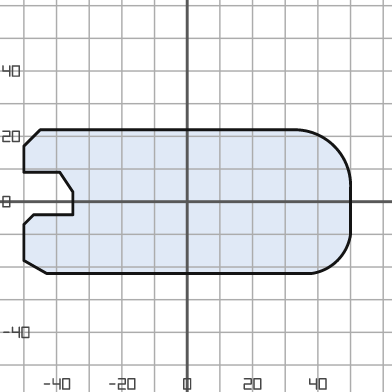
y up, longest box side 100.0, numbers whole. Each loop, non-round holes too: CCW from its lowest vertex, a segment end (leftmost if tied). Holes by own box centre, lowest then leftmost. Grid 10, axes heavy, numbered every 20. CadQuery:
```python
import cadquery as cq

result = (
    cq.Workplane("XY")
    .moveTo(-43.0, -22.0)
    .lineTo(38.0, -22.0)
    .threePointArc((46.0, -18.0), (50.0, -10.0))
    .lineTo(50.0, 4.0)
    .threePointArc((45.0, 17.0), (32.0, 22.0))
    .lineTo(-45.0, 22.0)
    .lineTo(-50.0, 17.0)
    .lineTo(-50.0, 9.0)
    .lineTo(-39.0, 9.0)
    .lineTo(-35.0, 3.0)
    .lineTo(-35.0, -4.0)
    .lineTo(-47.0, -4.0)
    .lineTo(-50.0, -7.0)
    .lineTo(-50.0, -18.0)
    .close()
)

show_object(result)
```